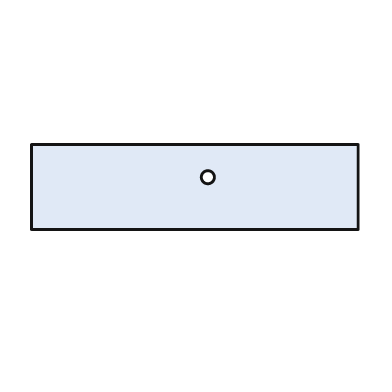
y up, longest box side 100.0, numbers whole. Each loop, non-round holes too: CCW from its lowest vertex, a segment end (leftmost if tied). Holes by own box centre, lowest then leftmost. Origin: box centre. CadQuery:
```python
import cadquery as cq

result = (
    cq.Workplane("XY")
    .moveTo(-50.0, -13.0)
    .lineTo(50.0, -13.0)
    .lineTo(50.0, 13.0)
    .lineTo(-50.0, 13.0)
    .close()
    .moveTo(4.0, 3.0)
    .circle(2.0)
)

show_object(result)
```